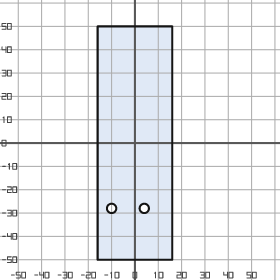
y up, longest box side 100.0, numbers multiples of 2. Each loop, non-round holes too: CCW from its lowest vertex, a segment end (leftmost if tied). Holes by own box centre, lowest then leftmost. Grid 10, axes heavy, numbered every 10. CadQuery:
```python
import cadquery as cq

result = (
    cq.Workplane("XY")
    .moveTo(-16.0, -50.0)
    .lineTo(16.0, -50.0)
    .lineTo(16.0, 50.0)
    .lineTo(-16.0, 50.0)
    .close()
    .moveTo(-10.0, -28.0)
    .circle(2.0)
    .moveTo(4.0, -28.0)
    .circle(2.0)
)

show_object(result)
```